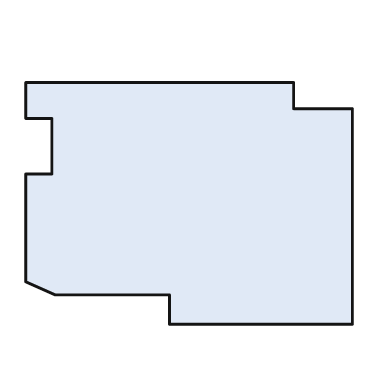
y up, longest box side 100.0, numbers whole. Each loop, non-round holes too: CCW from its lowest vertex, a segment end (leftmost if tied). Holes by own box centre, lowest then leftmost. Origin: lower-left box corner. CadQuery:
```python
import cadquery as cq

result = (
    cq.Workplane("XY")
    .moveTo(44.0, 0.0)
    .lineTo(100.0, 0.0)
    .lineTo(100.0, 66.0)
    .lineTo(82.0, 66.0)
    .lineTo(82.0, 74.0)
    .lineTo(0.0, 74.0)
    .lineTo(0.0, 63.0)
    .lineTo(8.0, 63.0)
    .lineTo(8.0, 46.0)
    .lineTo(0.0, 46.0)
    .lineTo(0.0, 13.0)
    .lineTo(9.0, 9.0)
    .lineTo(44.0, 9.0)
    .close()
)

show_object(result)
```